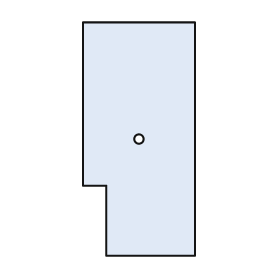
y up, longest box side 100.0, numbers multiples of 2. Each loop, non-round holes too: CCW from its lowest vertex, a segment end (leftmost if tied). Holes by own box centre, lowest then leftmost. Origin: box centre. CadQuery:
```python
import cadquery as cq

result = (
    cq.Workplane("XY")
    .moveTo(-14.0, -50.0)
    .lineTo(24.0, -50.0)
    .lineTo(24.0, 50.0)
    .lineTo(-24.0, 50.0)
    .lineTo(-24.0, -20.0)
    .lineTo(-14.0, -20.0)
    .close()
    .moveTo(0.0, 0.0)
    .circle(2.0)
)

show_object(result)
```